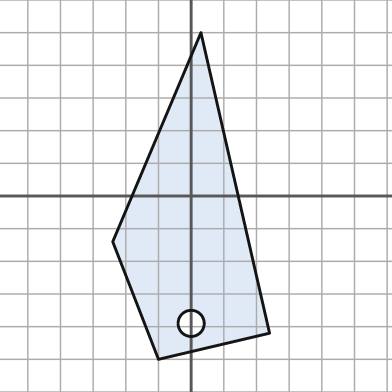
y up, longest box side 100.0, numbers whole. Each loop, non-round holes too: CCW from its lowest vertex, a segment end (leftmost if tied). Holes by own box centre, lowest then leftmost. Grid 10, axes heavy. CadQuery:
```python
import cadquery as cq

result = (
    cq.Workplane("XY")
    .moveTo(-10.0, -50.0)
    .lineTo(24.0, -42.0)
    .lineTo(3.0, 50.0)
    .lineTo(-24.0, -14.0)
    .close()
    .moveTo(0.0, -39.0)
    .circle(4.0)
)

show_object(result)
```